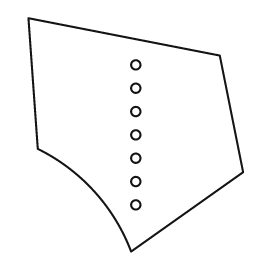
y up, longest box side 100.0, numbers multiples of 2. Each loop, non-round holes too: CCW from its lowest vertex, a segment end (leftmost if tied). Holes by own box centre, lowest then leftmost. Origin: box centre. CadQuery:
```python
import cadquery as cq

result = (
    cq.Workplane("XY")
    .moveTo(-2.0, -50.0)
    .lineTo(46.0, -16.0)
    .lineTo(36.0, 34.0)
    .lineTo(-46.0, 50.0)
    .lineTo(-42.0, -6.0)
    .threePointArc((-18.0, -24.0), (-2.0, -50.0))
    .close()
    .moveTo(0.0, -30.0)
    .circle(2.0)
    .moveTo(0.0, -20.0)
    .circle(2.0)
    .moveTo(0.0, -10.0)
    .circle(2.0)
    .moveTo(0.0, 0.0)
    .circle(2.0)
    .moveTo(0.0, 10.0)
    .circle(2.0)
    .moveTo(0.0, 20.0)
    .circle(2.0)
    .moveTo(0.0, 30.0)
    .circle(2.0)
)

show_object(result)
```